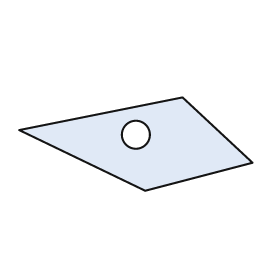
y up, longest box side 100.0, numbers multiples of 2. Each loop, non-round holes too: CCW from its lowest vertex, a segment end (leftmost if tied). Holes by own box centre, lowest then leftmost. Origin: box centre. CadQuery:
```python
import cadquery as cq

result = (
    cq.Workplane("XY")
    .moveTo(4.0, -20.0)
    .lineTo(50.0, -8.0)
    .lineTo(20.0, 20.0)
    .lineTo(-50.0, 6.0)
    .close()
    .moveTo(0.0, 4.0)
    .circle(6.0)
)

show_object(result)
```